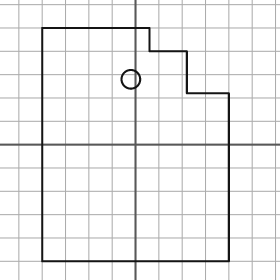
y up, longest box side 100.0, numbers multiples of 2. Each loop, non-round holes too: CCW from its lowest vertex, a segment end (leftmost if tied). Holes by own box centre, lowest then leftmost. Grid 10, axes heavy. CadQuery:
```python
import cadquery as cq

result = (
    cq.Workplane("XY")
    .moveTo(-40.0, -50.0)
    .lineTo(40.0, -50.0)
    .lineTo(40.0, 22.0)
    .lineTo(22.0, 22.0)
    .lineTo(22.0, 40.0)
    .lineTo(6.0, 40.0)
    .lineTo(6.0, 50.0)
    .lineTo(-40.0, 50.0)
    .close()
    .moveTo(-2.0, 28.0)
    .circle(4.0)
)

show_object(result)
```